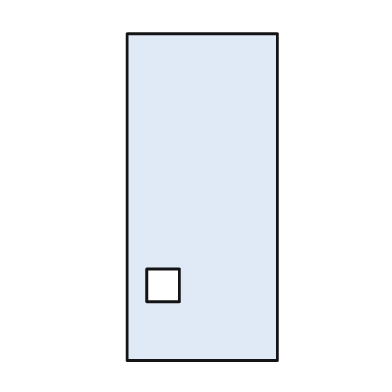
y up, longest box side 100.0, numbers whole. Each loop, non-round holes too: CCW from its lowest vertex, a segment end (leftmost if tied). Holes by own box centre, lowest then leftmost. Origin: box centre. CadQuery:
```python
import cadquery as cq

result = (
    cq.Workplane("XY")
    .moveTo(-23.0, -50.0)
    .lineTo(23.0, -50.0)
    .lineTo(23.0, 50.0)
    .lineTo(-23.0, 50.0)
    .close()
    .moveTo(-17.0, -32.0)
    .lineTo(-7.0, -32.0)
    .lineTo(-7.0, -22.0)
    .lineTo(-17.0, -22.0)
    .close()
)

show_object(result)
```